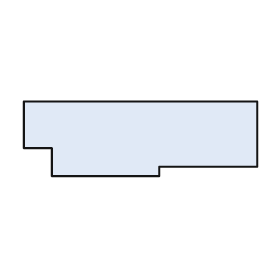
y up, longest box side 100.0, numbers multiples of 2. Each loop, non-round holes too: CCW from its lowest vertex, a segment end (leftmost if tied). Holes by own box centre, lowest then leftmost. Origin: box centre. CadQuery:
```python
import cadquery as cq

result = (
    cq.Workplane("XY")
    .moveTo(-38.0, -16.0)
    .lineTo(8.0, -16.0)
    .lineTo(8.0, -12.0)
    .lineTo(50.0, -12.0)
    .lineTo(50.0, 16.0)
    .lineTo(-50.0, 16.0)
    .lineTo(-50.0, -4.0)
    .lineTo(-38.0, -4.0)
    .close()
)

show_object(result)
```